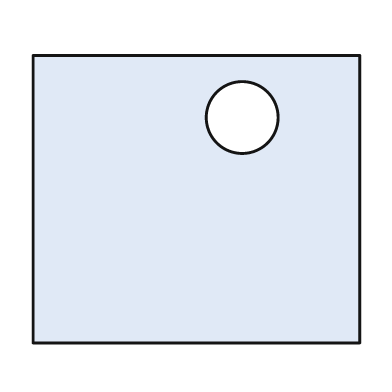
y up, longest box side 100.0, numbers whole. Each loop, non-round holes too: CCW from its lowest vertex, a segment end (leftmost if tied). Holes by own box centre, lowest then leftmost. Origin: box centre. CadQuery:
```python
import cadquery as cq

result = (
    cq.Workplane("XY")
    .moveTo(-50.0, -44.0)
    .lineTo(50.0, -44.0)
    .lineTo(50.0, 44.0)
    .lineTo(-50.0, 44.0)
    .close()
    .moveTo(14.0, 25.0)
    .circle(11.0)
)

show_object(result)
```